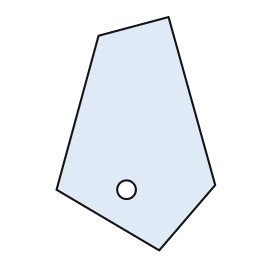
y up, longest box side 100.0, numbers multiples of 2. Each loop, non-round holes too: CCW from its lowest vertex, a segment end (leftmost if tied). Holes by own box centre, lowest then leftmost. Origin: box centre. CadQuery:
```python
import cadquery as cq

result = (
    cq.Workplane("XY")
    .moveTo(10.0, -50.0)
    .lineTo(34.0, -22.0)
    .lineTo(14.0, 50.0)
    .lineTo(-16.0, 42.0)
    .lineTo(-34.0, -24.0)
    .close()
    .moveTo(-4.0, -24.0)
    .circle(4.0)
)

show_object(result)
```